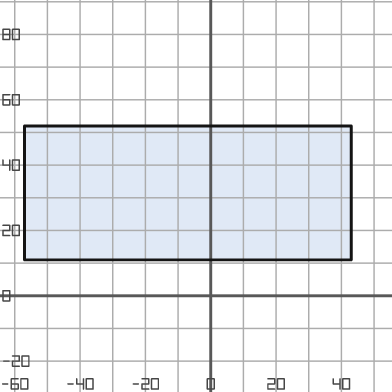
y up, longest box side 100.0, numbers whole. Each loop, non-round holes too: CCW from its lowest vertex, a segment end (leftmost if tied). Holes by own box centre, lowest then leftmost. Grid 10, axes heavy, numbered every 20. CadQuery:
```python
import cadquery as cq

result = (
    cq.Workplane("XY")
    .moveTo(-57.0, 11.0)
    .lineTo(43.0, 11.0)
    .lineTo(43.0, 52.0)
    .lineTo(-57.0, 52.0)
    .close()
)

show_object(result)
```